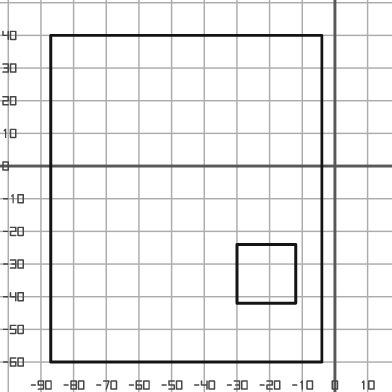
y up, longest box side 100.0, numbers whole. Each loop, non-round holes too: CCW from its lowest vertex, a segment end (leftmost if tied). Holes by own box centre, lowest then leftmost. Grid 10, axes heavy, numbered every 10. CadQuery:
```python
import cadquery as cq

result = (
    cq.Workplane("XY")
    .moveTo(-87.0, -60.0)
    .lineTo(-4.0, -60.0)
    .lineTo(-4.0, 40.0)
    .lineTo(-87.0, 40.0)
    .close()
    .moveTo(-30.0, -42.0)
    .lineTo(-12.0, -42.0)
    .lineTo(-12.0, -24.0)
    .lineTo(-30.0, -24.0)
    .close()
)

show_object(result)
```